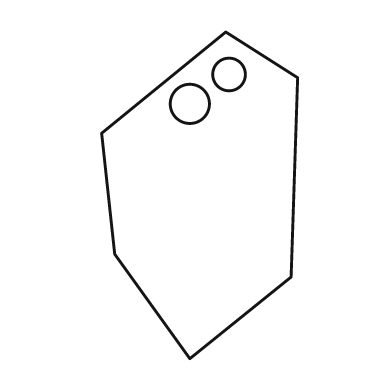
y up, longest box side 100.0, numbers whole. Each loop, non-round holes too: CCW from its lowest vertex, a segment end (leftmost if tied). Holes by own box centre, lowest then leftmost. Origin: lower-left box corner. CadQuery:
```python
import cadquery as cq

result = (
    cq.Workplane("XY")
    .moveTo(27.0, 0.0)
    .lineTo(58.0, 25.0)
    .lineTo(60.0, 86.0)
    .lineTo(38.0, 100.0)
    .lineTo(0.0, 69.0)
    .lineTo(4.0, 32.0)
    .close()
    .moveTo(27.0, 78.0)
    .circle(6.0)
    .moveTo(39.0, 87.0)
    .circle(5.0)
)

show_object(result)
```